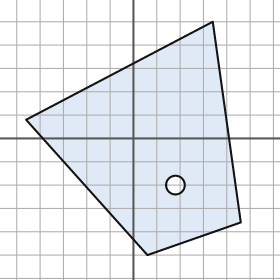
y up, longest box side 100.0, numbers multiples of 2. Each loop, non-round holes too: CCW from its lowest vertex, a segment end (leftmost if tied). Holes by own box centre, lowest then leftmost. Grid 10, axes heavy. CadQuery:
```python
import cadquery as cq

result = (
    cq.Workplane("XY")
    .moveTo(6.0, -50.0)
    .lineTo(46.0, -36.0)
    .lineTo(34.0, 50.0)
    .lineTo(-46.0, 8.0)
    .close()
    .moveTo(18.0, -20.0)
    .circle(4.0)
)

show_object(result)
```